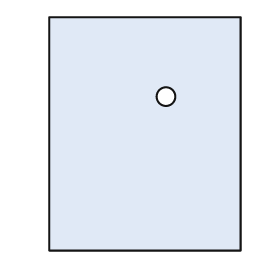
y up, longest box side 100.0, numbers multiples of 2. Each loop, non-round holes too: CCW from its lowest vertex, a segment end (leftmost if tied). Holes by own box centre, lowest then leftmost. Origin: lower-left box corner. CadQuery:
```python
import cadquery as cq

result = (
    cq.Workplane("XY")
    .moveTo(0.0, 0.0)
    .lineTo(82.0, 0.0)
    .lineTo(82.0, 100.0)
    .lineTo(0.0, 100.0)
    .close()
    .moveTo(50.0, 66.0)
    .circle(4.0)
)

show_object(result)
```